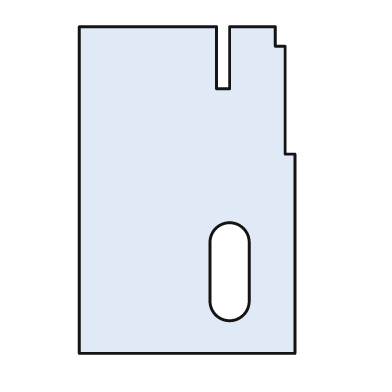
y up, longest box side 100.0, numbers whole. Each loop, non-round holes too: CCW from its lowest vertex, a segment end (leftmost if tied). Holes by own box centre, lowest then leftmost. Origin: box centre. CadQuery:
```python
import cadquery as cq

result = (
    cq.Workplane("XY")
    .moveTo(-33.0, -50.0)
    .lineTo(33.0, -50.0)
    .lineTo(33.0, 11.0)
    .lineTo(30.0, 11.0)
    .lineTo(30.0, 44.0)
    .lineTo(27.0, 44.0)
    .lineTo(27.0, 50.0)
    .lineTo(13.0, 50.0)
    .lineTo(13.0, 31.0)
    .lineTo(9.0, 31.0)
    .lineTo(9.0, 50.0)
    .lineTo(-33.0, 50.0)
    .close()
    .moveTo(7.0, -34.0)
    .threePointArc((13.0, -40.0), (19.0, -34.0))
    .lineTo(19.0, -16.0)
    .threePointArc((13.0, -10.0), (7.0, -16.0))
    .close()
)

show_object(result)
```